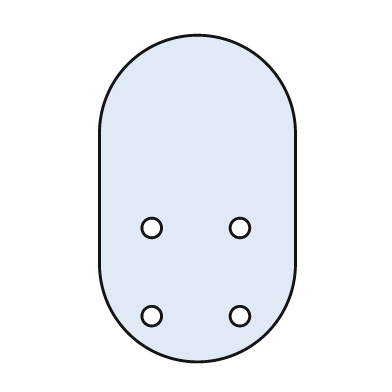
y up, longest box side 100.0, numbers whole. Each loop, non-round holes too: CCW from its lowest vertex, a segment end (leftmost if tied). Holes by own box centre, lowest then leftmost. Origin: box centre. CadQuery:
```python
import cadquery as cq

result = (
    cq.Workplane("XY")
    .moveTo(-30.0, -20.0)
    .threePointArc((0.0, -50.0), (30.0, -20.0))
    .lineTo(30.0, 20.0)
    .threePointArc((0.0, 50.0), (-30.0, 20.0))
    .close()
    .moveTo(-14.0, -36.0)
    .circle(3.0)
    .moveTo(13.0, -36.0)
    .circle(3.0)
    .moveTo(-14.0, -9.0)
    .circle(3.0)
    .moveTo(13.0, -9.0)
    .circle(3.0)
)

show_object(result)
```